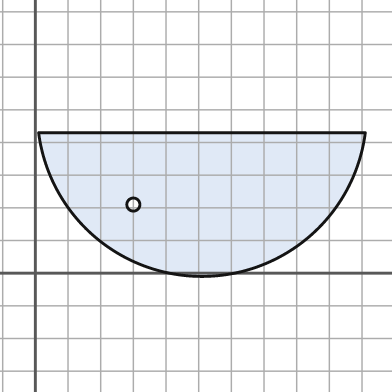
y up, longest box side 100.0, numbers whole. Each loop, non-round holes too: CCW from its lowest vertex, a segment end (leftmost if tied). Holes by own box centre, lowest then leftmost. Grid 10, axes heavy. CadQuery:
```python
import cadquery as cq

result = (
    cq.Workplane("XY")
    .moveTo(1.0, 43.0)
    .threePointArc((51.0, -1.0), (101.0, 43.0))
    .close()
    .moveTo(30.0, 21.0)
    .circle(2.0)
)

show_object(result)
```